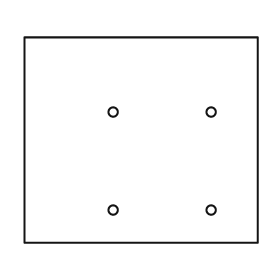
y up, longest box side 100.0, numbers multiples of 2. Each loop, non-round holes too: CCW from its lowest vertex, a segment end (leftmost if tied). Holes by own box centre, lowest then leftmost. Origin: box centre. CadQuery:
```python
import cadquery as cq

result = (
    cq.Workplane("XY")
    .moveTo(-50.0, -44.0)
    .lineTo(50.0, -44.0)
    .lineTo(50.0, 44.0)
    .lineTo(-50.0, 44.0)
    .close()
    .moveTo(-12.0, -30.0)
    .circle(2.0)
    .moveTo(30.0, -30.0)
    .circle(2.0)
    .moveTo(-12.0, 12.0)
    .circle(2.0)
    .moveTo(30.0, 12.0)
    .circle(2.0)
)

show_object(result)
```